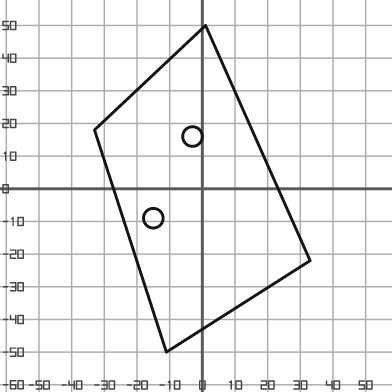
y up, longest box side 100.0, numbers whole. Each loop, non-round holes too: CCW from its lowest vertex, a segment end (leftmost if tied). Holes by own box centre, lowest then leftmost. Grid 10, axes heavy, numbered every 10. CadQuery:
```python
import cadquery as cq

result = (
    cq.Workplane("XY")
    .moveTo(-11.0, -50.0)
    .lineTo(33.0, -22.0)
    .lineTo(1.0, 50.0)
    .lineTo(-33.0, 18.0)
    .close()
    .moveTo(-15.0, -9.0)
    .circle(3.0)
    .moveTo(-3.0, 16.0)
    .circle(3.0)
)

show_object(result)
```